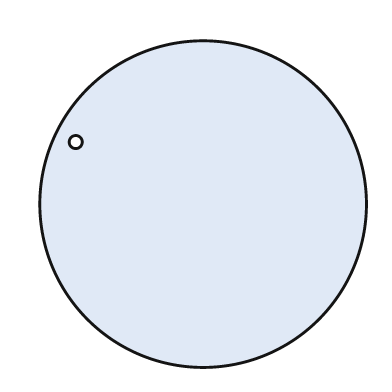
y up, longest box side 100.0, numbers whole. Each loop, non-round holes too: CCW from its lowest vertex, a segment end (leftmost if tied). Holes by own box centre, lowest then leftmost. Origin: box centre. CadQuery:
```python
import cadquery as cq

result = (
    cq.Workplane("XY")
    .moveTo(0.0, 0.0)
    .circle(50.0)
    .moveTo(-39.0, 19.0)
    .circle(2.0)
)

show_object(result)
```